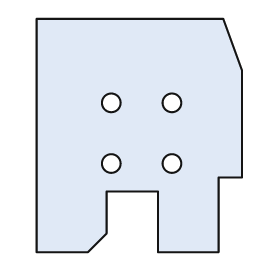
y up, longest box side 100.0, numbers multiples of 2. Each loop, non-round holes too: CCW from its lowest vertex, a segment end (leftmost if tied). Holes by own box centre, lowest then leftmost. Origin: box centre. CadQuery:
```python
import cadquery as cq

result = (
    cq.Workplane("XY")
    .moveTo(-44.0, -50.0)
    .lineTo(-22.0, -50.0)
    .lineTo(-14.0, -42.0)
    .lineTo(-14.0, -24.0)
    .lineTo(8.0, -24.0)
    .lineTo(8.0, -50.0)
    .lineTo(34.0, -50.0)
    .lineTo(34.0, -18.0)
    .lineTo(44.0, -18.0)
    .lineTo(44.0, 28.0)
    .lineTo(36.0, 50.0)
    .lineTo(-44.0, 50.0)
    .close()
    .moveTo(-12.0, -12.0)
    .circle(4.0)
    .moveTo(14.0, -12.0)
    .circle(4.0)
    .moveTo(-12.0, 14.0)
    .circle(4.0)
    .moveTo(14.0, 14.0)
    .circle(4.0)
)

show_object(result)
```